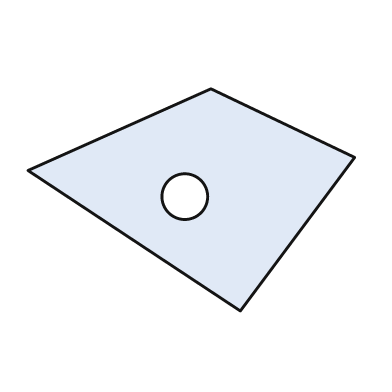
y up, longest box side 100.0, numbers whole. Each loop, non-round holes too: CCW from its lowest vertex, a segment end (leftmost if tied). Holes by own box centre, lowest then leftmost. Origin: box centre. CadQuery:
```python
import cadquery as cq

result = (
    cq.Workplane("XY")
    .moveTo(15.0, -34.0)
    .lineTo(50.0, 13.0)
    .lineTo(6.0, 34.0)
    .lineTo(-50.0, 9.0)
    .close()
    .moveTo(-2.0, 1.0)
    .circle(7.0)
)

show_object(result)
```